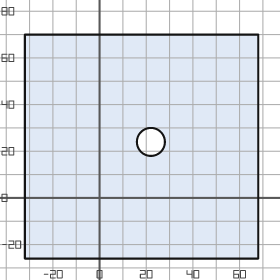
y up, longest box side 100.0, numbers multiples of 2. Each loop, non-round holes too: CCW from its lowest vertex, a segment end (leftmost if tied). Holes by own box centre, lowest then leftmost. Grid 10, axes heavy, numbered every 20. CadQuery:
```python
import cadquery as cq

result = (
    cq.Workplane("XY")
    .moveTo(-32.0, -26.0)
    .lineTo(68.0, -26.0)
    .lineTo(68.0, 70.0)
    .lineTo(-32.0, 70.0)
    .close()
    .moveTo(22.0, 24.0)
    .circle(6.0)
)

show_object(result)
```